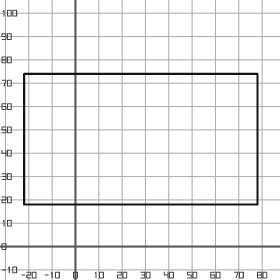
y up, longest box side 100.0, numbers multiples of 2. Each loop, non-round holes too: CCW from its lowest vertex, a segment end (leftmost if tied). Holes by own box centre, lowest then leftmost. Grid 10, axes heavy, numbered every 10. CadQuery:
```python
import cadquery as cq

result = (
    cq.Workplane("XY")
    .moveTo(-22.0, 18.0)
    .lineTo(78.0, 18.0)
    .lineTo(78.0, 74.0)
    .lineTo(-22.0, 74.0)
    .close()
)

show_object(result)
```